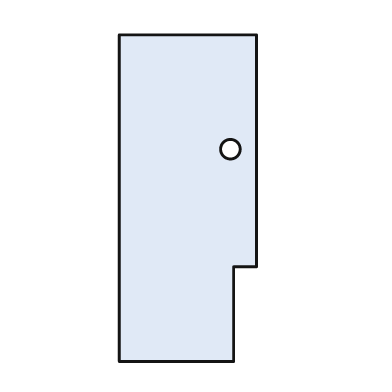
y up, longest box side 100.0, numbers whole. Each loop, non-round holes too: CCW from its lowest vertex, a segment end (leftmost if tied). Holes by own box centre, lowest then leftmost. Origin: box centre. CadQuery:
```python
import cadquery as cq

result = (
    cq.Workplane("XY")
    .moveTo(-21.0, -50.0)
    .lineTo(14.0, -50.0)
    .lineTo(14.0, -21.0)
    .lineTo(21.0, -21.0)
    .lineTo(21.0, 50.0)
    .lineTo(-21.0, 50.0)
    .close()
    .moveTo(13.0, 15.0)
    .circle(3.0)
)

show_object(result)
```